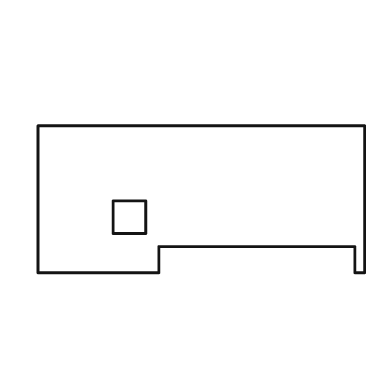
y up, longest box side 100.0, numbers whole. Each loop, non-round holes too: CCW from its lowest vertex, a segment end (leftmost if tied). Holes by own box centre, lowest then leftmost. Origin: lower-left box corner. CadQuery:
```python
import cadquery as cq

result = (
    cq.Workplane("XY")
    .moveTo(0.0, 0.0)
    .lineTo(37.0, 0.0)
    .lineTo(37.0, 8.0)
    .lineTo(97.0, 8.0)
    .lineTo(97.0, 0.0)
    .lineTo(100.0, 0.0)
    .lineTo(100.0, 45.0)
    .lineTo(0.0, 45.0)
    .close()
    .moveTo(23.0, 12.0)
    .lineTo(33.0, 12.0)
    .lineTo(33.0, 22.0)
    .lineTo(23.0, 22.0)
    .close()
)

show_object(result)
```